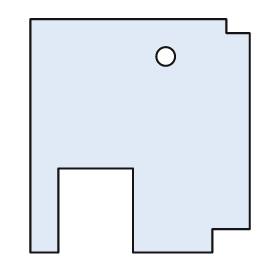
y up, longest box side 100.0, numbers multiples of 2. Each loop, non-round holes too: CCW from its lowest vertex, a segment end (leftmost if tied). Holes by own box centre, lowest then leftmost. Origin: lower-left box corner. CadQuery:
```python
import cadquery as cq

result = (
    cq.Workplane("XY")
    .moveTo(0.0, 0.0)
    .lineTo(12.0, 0.0)
    .lineTo(12.0, 36.0)
    .lineTo(44.0, 36.0)
    .lineTo(44.0, 0.0)
    .lineTo(78.0, 0.0)
    .lineTo(78.0, 10.0)
    .lineTo(94.0, 10.0)
    .lineTo(94.0, 94.0)
    .lineTo(84.0, 94.0)
    .lineTo(84.0, 100.0)
    .lineTo(0.0, 100.0)
    .close()
    .moveTo(58.0, 84.0)
    .circle(4.0)
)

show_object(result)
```